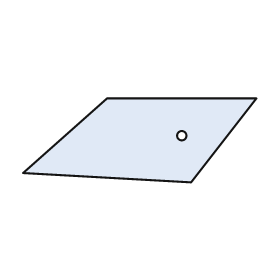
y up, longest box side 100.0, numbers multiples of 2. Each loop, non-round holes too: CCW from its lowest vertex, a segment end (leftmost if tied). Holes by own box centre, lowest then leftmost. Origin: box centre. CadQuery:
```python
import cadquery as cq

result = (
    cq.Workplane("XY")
    .moveTo(22.0, -18.0)
    .lineTo(50.0, 18.0)
    .lineTo(-14.0, 18.0)
    .lineTo(-50.0, -14.0)
    .close()
    .moveTo(18.0, 2.0)
    .circle(2.0)
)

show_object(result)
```